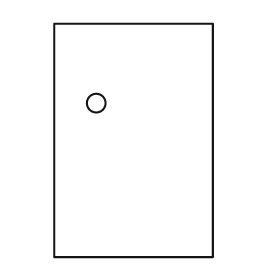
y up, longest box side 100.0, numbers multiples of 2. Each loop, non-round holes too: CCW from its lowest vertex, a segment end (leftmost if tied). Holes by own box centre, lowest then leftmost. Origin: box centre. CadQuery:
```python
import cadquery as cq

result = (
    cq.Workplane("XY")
    .moveTo(-34.0, -50.0)
    .lineTo(34.0, -50.0)
    .lineTo(34.0, 50.0)
    .lineTo(-34.0, 50.0)
    .close()
    .moveTo(-16.0, 16.0)
    .circle(4.0)
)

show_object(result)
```